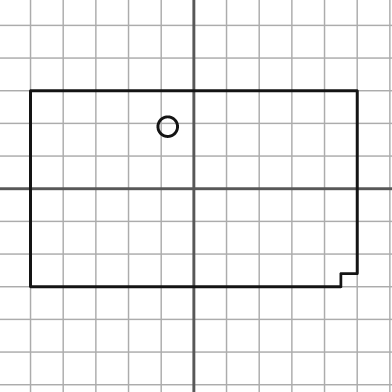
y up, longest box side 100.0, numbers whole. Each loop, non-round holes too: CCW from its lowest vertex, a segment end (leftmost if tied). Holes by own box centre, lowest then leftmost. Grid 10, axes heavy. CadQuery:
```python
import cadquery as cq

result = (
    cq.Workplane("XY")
    .moveTo(-50.0, -30.0)
    .lineTo(45.0, -30.0)
    .lineTo(45.0, -26.0)
    .lineTo(50.0, -26.0)
    .lineTo(50.0, 30.0)
    .lineTo(-50.0, 30.0)
    .close()
    .moveTo(-8.0, 19.0)
    .circle(3.0)
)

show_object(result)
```